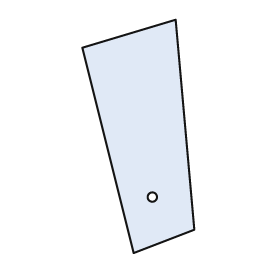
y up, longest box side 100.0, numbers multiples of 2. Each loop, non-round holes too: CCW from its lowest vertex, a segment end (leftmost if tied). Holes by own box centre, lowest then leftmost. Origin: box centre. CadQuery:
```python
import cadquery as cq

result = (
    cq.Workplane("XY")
    .moveTo(-2.0, -50.0)
    .lineTo(24.0, -40.0)
    .lineTo(16.0, 50.0)
    .lineTo(-24.0, 38.0)
    .close()
    .moveTo(6.0, -26.0)
    .circle(2.0)
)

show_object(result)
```